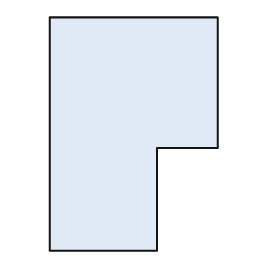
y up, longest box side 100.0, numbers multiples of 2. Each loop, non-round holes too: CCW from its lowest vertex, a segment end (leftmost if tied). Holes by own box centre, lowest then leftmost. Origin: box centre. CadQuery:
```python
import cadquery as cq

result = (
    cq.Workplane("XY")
    .moveTo(-36.0, -50.0)
    .lineTo(10.0, -50.0)
    .lineTo(10.0, -6.0)
    .lineTo(36.0, -6.0)
    .lineTo(36.0, 50.0)
    .lineTo(-36.0, 50.0)
    .close()
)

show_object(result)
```